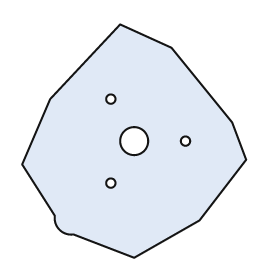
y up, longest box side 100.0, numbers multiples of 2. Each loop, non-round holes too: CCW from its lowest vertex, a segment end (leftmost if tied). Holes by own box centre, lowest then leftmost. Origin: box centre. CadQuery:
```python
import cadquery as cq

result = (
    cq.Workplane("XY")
    .moveTo(0.0, -50.0)
    .lineTo(28.0, -34.0)
    .lineTo(48.0, -8.0)
    .lineTo(42.0, 8.0)
    .lineTo(16.0, 40.0)
    .lineTo(-6.0, 50.0)
    .lineTo(-36.0, 18.0)
    .lineTo(-48.0, -10.0)
    .lineTo(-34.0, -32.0)
    .threePointArc((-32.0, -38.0), (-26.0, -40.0))
    .close()
    .moveTo(-10.0, -18.0)
    .circle(2.0)
    .moveTo(0.0, 0.0)
    .circle(6.0)
    .moveTo(22.0, 0.0)
    .circle(2.0)
    .moveTo(-10.0, 18.0)
    .circle(2.0)
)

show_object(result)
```